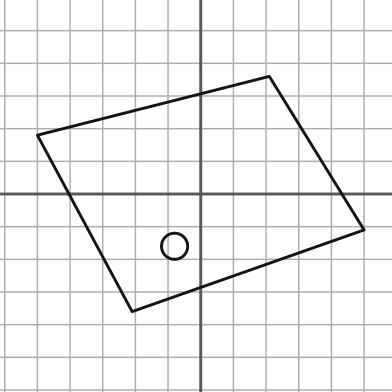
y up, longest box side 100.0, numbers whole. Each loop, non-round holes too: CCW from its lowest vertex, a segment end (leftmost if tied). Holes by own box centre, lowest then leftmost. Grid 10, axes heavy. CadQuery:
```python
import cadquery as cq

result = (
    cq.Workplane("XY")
    .moveTo(-21.0, -36.0)
    .lineTo(50.0, -11.0)
    .lineTo(21.0, 36.0)
    .lineTo(-50.0, 18.0)
    .close()
    .moveTo(-8.0, -16.0)
    .circle(4.0)
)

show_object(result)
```